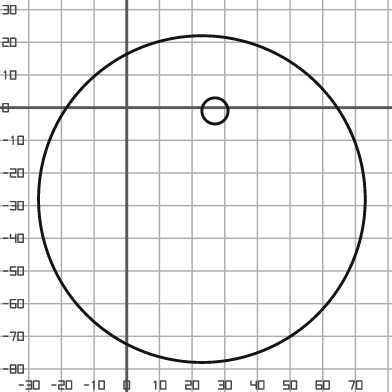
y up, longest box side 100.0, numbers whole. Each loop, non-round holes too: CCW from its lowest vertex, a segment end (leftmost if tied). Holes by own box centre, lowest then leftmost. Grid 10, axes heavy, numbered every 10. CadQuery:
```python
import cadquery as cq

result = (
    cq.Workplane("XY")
    .moveTo(23.0, -28.0)
    .circle(50.0)
    .moveTo(27.0, -1.0)
    .circle(4.0)
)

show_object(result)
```